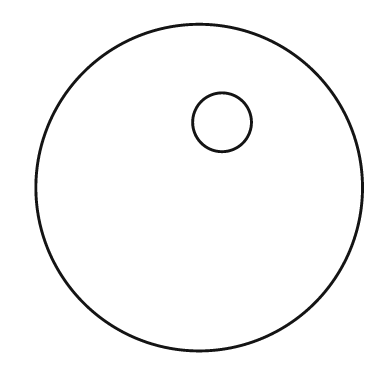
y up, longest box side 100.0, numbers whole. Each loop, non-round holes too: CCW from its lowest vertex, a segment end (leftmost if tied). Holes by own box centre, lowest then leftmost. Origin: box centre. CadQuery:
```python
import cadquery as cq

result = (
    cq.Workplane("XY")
    .moveTo(0.0, 0.0)
    .circle(50.0)
    .moveTo(7.0, 20.0)
    .circle(9.0)
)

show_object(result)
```